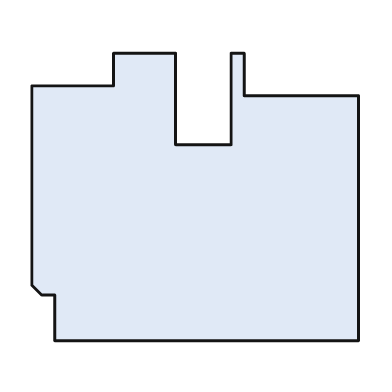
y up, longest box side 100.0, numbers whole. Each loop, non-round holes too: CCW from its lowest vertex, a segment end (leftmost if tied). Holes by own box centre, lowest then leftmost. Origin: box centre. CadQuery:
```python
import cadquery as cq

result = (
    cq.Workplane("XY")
    .moveTo(-43.0, -44.0)
    .lineTo(50.0, -44.0)
    .lineTo(50.0, 31.0)
    .lineTo(15.0, 31.0)
    .lineTo(15.0, 44.0)
    .lineTo(11.0, 44.0)
    .lineTo(11.0, 16.0)
    .lineTo(-6.0, 16.0)
    .lineTo(-6.0, 44.0)
    .lineTo(-25.0, 44.0)
    .lineTo(-25.0, 34.0)
    .lineTo(-50.0, 34.0)
    .lineTo(-50.0, -27.0)
    .lineTo(-47.0, -30.0)
    .lineTo(-43.0, -30.0)
    .close()
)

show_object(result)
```